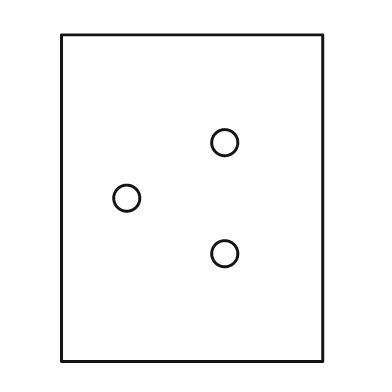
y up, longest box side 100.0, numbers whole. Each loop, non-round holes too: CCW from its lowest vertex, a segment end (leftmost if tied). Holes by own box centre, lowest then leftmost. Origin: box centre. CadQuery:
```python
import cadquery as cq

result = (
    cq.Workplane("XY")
    .moveTo(-40.0, -50.0)
    .lineTo(40.0, -50.0)
    .lineTo(40.0, 50.0)
    .lineTo(-40.0, 50.0)
    .close()
    .moveTo(10.0, -17.0)
    .circle(4.0)
    .moveTo(-20.0, 0.0)
    .circle(4.0)
    .moveTo(10.0, 17.0)
    .circle(4.0)
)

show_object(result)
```